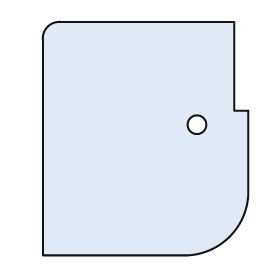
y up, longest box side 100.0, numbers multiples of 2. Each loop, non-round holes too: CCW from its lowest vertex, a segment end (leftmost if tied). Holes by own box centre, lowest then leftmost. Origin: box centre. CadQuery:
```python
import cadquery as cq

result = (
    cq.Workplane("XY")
    .moveTo(-44.0, -50.0)
    .lineTo(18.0, -50.0)
    .threePointArc((36.0, -42.0), (44.0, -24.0))
    .lineTo(44.0, 12.0)
    .lineTo(38.0, 12.0)
    .lineTo(38.0, 50.0)
    .lineTo(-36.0, 50.0)
    .threePointArc((-42.0, 48.0), (-44.0, 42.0))
    .close()
    .moveTo(22.0, 6.0)
    .circle(4.0)
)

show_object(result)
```